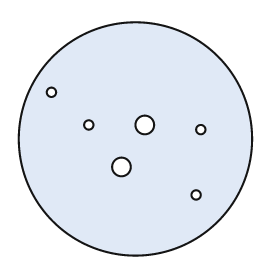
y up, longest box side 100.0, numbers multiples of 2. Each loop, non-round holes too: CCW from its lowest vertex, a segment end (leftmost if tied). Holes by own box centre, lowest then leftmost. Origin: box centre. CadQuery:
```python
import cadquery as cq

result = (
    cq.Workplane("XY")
    .moveTo(0.0, 0.0)
    .circle(50.0)
    .moveTo(26.0, -24.0)
    .circle(2.0)
    .moveTo(-6.0, -12.0)
    .circle(4.0)
    .moveTo(28.0, 4.0)
    .circle(2.0)
    .moveTo(-20.0, 6.0)
    .circle(2.0)
    .moveTo(4.0, 6.0)
    .circle(4.0)
    .moveTo(-36.0, 20.0)
    .circle(2.0)
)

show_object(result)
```